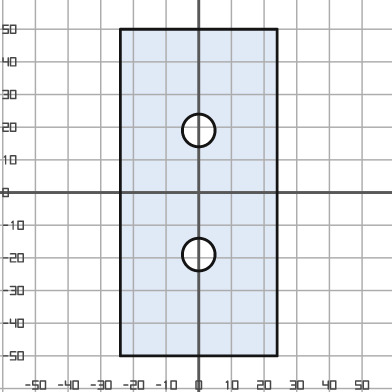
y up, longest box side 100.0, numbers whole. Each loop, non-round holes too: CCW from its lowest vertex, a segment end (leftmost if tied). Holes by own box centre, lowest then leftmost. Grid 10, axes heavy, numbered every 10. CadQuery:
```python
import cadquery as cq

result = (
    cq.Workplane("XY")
    .moveTo(-24.0, -50.0)
    .lineTo(24.0, -50.0)
    .lineTo(24.0, 50.0)
    .lineTo(-24.0, 50.0)
    .close()
    .moveTo(0.0, -19.0)
    .circle(5.0)
    .moveTo(0.0, 19.0)
    .circle(5.0)
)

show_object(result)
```